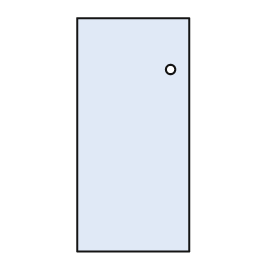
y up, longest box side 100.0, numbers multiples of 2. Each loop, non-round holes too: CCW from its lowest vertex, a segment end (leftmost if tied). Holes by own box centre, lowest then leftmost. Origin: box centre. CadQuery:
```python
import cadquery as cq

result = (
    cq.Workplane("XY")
    .moveTo(-24.0, -50.0)
    .lineTo(24.0, -50.0)
    .lineTo(24.0, 50.0)
    .lineTo(-24.0, 50.0)
    .close()
    .moveTo(16.0, 28.0)
    .circle(2.0)
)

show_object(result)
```